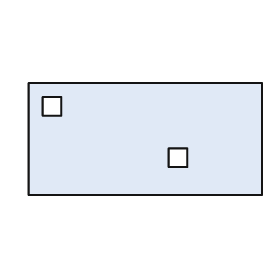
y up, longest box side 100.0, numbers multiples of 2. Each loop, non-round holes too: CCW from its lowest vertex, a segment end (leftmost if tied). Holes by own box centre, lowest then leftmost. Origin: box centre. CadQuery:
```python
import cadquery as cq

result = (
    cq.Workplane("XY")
    .moveTo(-50.0, -24.0)
    .lineTo(50.0, -24.0)
    .lineTo(50.0, 24.0)
    .lineTo(-50.0, 24.0)
    .close()
    .moveTo(10.0, -12.0)
    .lineTo(18.0, -12.0)
    .lineTo(18.0, -4.0)
    .lineTo(10.0, -4.0)
    .close()
    .moveTo(-44.0, 10.0)
    .lineTo(-36.0, 10.0)
    .lineTo(-36.0, 18.0)
    .lineTo(-44.0, 18.0)
    .close()
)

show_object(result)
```